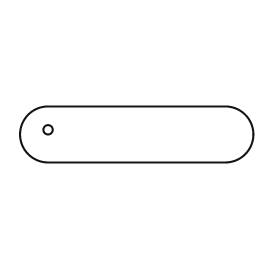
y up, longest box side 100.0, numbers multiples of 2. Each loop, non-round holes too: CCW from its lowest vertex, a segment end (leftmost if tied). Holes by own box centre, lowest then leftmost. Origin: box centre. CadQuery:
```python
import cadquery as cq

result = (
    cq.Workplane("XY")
    .moveTo(-38.0, -12.0)
    .lineTo(38.0, -12.0)
    .threePointArc((50.0, 0.0), (38.0, 12.0))
    .lineTo(-38.0, 12.0)
    .threePointArc((-50.0, 0.0), (-38.0, -12.0))
    .close()
    .moveTo(-38.0, 2.0)
    .circle(2.0)
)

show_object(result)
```